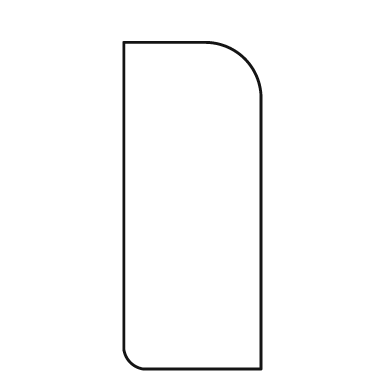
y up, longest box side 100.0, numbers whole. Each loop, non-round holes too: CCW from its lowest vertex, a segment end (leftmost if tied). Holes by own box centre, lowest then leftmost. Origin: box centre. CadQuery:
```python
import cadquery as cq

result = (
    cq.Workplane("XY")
    .moveTo(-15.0, -50.0)
    .lineTo(21.0, -50.0)
    .lineTo(21.0, 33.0)
    .threePointArc((16.0, 45.0), (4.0, 50.0))
    .lineTo(-21.0, 50.0)
    .lineTo(-21.0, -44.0)
    .threePointArc((-19.0, -48.0), (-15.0, -50.0))
    .close()
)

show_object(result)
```